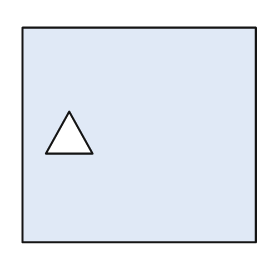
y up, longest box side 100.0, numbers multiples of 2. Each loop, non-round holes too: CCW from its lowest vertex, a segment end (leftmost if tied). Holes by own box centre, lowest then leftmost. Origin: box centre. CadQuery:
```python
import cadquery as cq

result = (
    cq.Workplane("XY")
    .moveTo(-50.0, -46.0)
    .lineTo(50.0, -46.0)
    .lineTo(50.0, 46.0)
    .lineTo(-50.0, 46.0)
    .close()
    .moveTo(-40.0, -8.0)
    .lineTo(-20.0, -8.0)
    .lineTo(-30.0, 10.0)
    .close()
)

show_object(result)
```